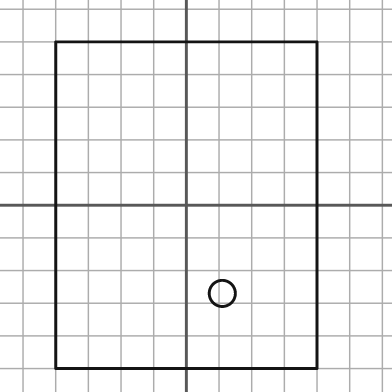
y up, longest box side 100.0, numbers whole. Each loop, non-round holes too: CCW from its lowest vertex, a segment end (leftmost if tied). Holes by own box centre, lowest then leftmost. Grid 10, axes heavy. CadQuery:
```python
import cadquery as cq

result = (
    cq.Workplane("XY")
    .moveTo(-40.0, -50.0)
    .lineTo(40.0, -50.0)
    .lineTo(40.0, 50.0)
    .lineTo(-40.0, 50.0)
    .close()
    .moveTo(11.0, -27.0)
    .circle(4.0)
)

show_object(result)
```